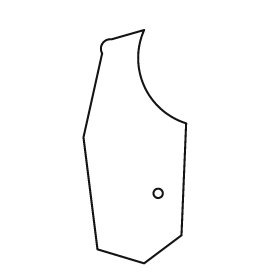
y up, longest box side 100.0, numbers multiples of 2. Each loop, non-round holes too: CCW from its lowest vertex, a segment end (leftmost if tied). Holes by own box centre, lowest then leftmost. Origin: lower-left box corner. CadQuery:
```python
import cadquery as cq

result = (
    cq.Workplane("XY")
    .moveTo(26.0, 0.0)
    .lineTo(42.0, 12.0)
    .lineTo(44.0, 60.0)
    .threePointArc((26.0, 76.0), (26.0, 100.0))
    .lineTo(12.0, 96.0)
    .threePointArc((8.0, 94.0), (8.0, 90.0))
    .lineTo(0.0, 54.0)
    .lineTo(6.0, 6.0)
    .close()
    .moveTo(32.0, 30.0)
    .circle(2.0)
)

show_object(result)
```